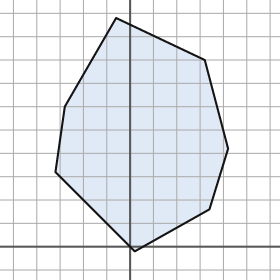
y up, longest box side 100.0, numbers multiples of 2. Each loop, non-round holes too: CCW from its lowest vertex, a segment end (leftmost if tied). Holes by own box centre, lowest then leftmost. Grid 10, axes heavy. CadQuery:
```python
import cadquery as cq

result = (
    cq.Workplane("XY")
    .moveTo(2.0, -2.0)
    .lineTo(34.0, 16.0)
    .lineTo(42.0, 42.0)
    .lineTo(32.0, 80.0)
    .lineTo(-6.0, 98.0)
    .lineTo(-28.0, 60.0)
    .lineTo(-32.0, 32.0)
    .close()
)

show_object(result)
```